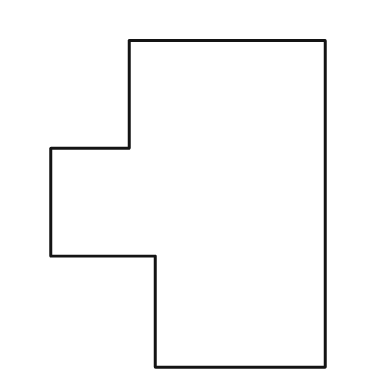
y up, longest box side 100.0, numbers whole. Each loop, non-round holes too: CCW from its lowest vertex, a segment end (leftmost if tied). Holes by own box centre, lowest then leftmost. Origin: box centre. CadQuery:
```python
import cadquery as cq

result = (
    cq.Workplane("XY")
    .moveTo(-10.0, -50.0)
    .lineTo(42.0, -50.0)
    .lineTo(42.0, 50.0)
    .lineTo(-18.0, 50.0)
    .lineTo(-18.0, 17.0)
    .lineTo(-42.0, 17.0)
    .lineTo(-42.0, -16.0)
    .lineTo(-10.0, -16.0)
    .close()
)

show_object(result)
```